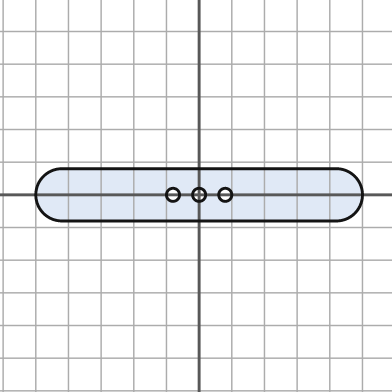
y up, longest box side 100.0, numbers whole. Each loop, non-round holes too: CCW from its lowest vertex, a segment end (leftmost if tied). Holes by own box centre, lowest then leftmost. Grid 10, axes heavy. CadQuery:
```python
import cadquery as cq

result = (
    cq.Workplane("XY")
    .moveTo(-42.0, -8.0)
    .lineTo(42.0, -8.0)
    .threePointArc((50.0, 0.0), (42.0, 8.0))
    .lineTo(-42.0, 8.0)
    .threePointArc((-50.0, 0.0), (-42.0, -8.0))
    .close()
    .moveTo(-8.0, 0.0)
    .circle(2.0)
    .moveTo(0.0, 0.0)
    .circle(2.0)
    .moveTo(8.0, 0.0)
    .circle(2.0)
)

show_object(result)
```